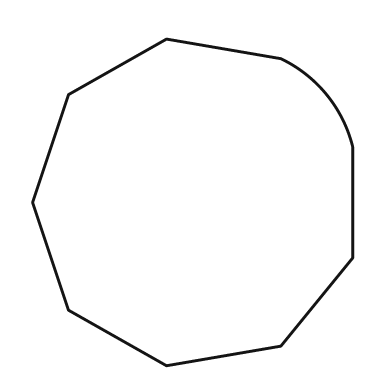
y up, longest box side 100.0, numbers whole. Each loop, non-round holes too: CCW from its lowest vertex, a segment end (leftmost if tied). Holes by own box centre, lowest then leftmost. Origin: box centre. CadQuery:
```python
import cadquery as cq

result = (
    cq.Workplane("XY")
    .moveTo(-8.0, -50.0)
    .lineTo(27.0, -44.0)
    .lineTo(49.0, -17.0)
    .lineTo(49.0, 17.0)
    .threePointArc((41.0, 33.0), (27.0, 44.0))
    .lineTo(-8.0, 50.0)
    .lineTo(-38.0, 33.0)
    .lineTo(-49.0, 0.0)
    .lineTo(-38.0, -33.0)
    .close()
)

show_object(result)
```